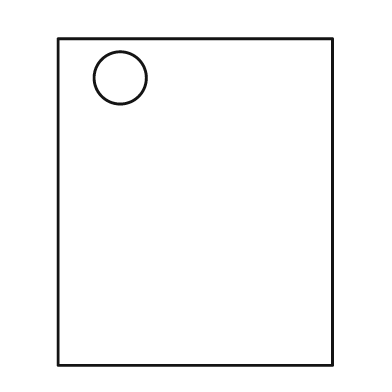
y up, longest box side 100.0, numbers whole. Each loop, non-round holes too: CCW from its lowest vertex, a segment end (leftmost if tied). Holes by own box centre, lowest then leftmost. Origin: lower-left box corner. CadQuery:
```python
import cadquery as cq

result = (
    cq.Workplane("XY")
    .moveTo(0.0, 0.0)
    .lineTo(84.0, 0.0)
    .lineTo(84.0, 100.0)
    .lineTo(0.0, 100.0)
    .close()
    .moveTo(19.0, 88.0)
    .circle(8.0)
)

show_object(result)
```